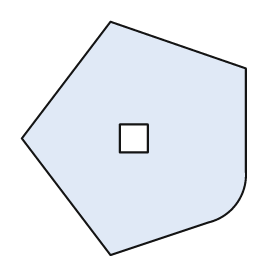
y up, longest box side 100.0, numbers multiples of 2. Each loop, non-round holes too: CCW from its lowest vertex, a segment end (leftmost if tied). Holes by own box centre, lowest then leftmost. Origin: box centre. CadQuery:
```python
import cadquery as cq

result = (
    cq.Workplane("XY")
    .moveTo(-10.0, -50.0)
    .lineTo(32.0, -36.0)
    .threePointArc((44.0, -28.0), (48.0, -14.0))
    .lineTo(48.0, 30.0)
    .lineTo(-10.0, 50.0)
    .lineTo(-48.0, 0.0)
    .close()
    .moveTo(-6.0, -6.0)
    .lineTo(6.0, -6.0)
    .lineTo(6.0, 6.0)
    .lineTo(-6.0, 6.0)
    .close()
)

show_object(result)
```